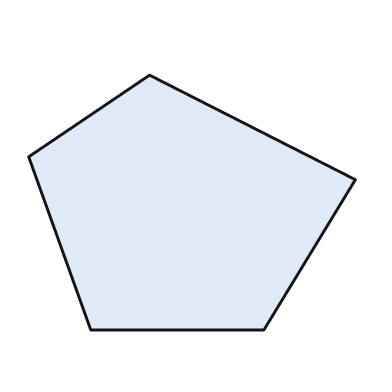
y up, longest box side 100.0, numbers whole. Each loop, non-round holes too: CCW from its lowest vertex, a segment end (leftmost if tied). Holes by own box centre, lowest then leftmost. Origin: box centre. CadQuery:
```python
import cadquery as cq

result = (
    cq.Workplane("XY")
    .moveTo(-31.0, -39.0)
    .lineTo(22.0, -39.0)
    .lineTo(50.0, 7.0)
    .lineTo(-13.0, 39.0)
    .lineTo(-50.0, 14.0)
    .close()
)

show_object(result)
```